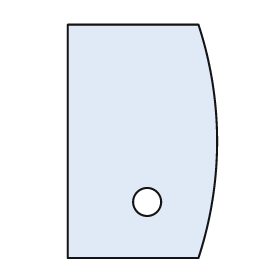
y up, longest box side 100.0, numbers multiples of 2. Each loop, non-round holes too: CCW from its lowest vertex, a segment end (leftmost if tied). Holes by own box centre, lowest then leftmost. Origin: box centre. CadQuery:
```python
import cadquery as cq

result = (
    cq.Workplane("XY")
    .moveTo(-32.0, -50.0)
    .lineTo(24.0, -50.0)
    .threePointArc((32.0, 0.0), (24.0, 50.0))
    .lineTo(-32.0, 50.0)
    .close()
    .moveTo(2.0, -26.0)
    .circle(6.0)
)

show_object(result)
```